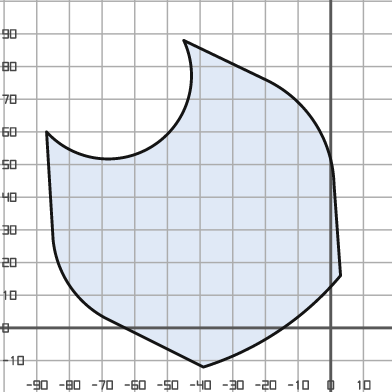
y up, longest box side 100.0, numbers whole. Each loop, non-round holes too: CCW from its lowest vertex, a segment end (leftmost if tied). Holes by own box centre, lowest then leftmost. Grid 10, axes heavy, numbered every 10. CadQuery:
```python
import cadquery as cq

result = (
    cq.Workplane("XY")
    .moveTo(-39.0, -12.0)
    .threePointArc((-16.0, -1.0), (3.0, 16.0))
    .lineTo(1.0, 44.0)
    .threePointArc((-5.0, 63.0), (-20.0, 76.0))
    .lineTo(-45.0, 88.0)
    .threePointArc((-54.0, 56.0), (-87.0, 60.0))
    .lineTo(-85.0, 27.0)
    .threePointArc((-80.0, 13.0), (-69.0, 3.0))
    .close()
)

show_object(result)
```